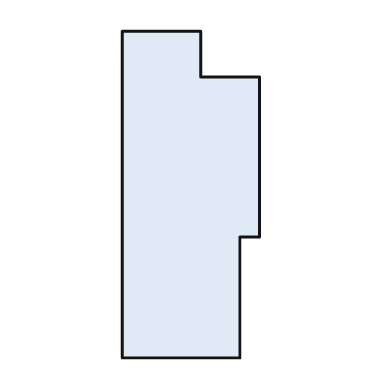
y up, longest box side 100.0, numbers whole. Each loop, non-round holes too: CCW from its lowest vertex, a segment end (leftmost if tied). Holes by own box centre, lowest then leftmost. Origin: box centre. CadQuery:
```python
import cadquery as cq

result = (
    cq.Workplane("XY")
    .moveTo(-21.0, -50.0)
    .lineTo(15.0, -50.0)
    .lineTo(15.0, -13.0)
    .lineTo(21.0, -13.0)
    .lineTo(21.0, 36.0)
    .lineTo(3.0, 36.0)
    .lineTo(3.0, 50.0)
    .lineTo(-21.0, 50.0)
    .close()
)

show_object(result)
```